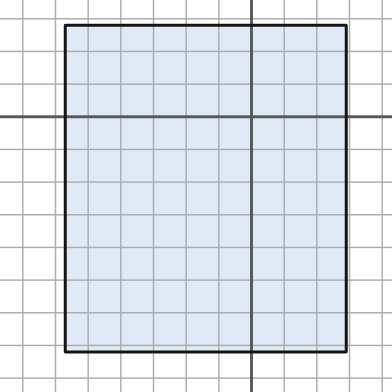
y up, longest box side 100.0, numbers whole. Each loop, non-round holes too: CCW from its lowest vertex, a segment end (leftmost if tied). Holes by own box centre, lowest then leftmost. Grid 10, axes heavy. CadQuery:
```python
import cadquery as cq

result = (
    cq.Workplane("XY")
    .moveTo(-57.0, -72.0)
    .lineTo(29.0, -72.0)
    .lineTo(29.0, 28.0)
    .lineTo(-57.0, 28.0)
    .close()
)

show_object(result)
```